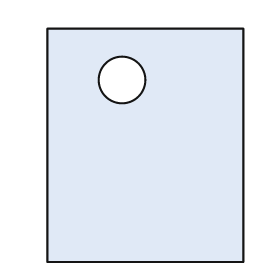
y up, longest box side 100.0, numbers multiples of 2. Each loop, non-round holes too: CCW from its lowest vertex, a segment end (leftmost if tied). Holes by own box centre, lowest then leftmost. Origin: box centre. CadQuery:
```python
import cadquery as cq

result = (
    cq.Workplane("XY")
    .moveTo(-42.0, -50.0)
    .lineTo(42.0, -50.0)
    .lineTo(42.0, 50.0)
    .lineTo(-42.0, 50.0)
    .close()
    .moveTo(-10.0, 28.0)
    .circle(10.0)
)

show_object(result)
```